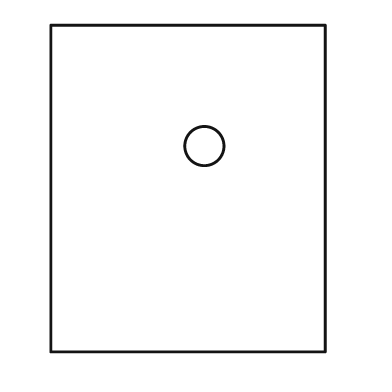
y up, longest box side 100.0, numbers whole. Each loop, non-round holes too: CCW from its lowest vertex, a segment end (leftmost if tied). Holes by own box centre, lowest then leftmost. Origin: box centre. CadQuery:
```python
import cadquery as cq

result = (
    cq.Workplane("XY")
    .moveTo(-42.0, -50.0)
    .lineTo(42.0, -50.0)
    .lineTo(42.0, 50.0)
    .lineTo(-42.0, 50.0)
    .close()
    .moveTo(5.0, 13.0)
    .circle(6.0)
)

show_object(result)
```